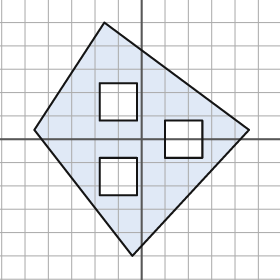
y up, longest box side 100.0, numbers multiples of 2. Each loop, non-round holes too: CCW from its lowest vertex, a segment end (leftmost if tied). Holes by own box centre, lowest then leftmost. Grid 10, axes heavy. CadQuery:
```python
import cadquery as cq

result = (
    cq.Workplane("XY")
    .moveTo(-4.0, -50.0)
    .lineTo(46.0, 4.0)
    .lineTo(-16.0, 50.0)
    .lineTo(-46.0, 4.0)
    .close()
    .moveTo(-18.0, -24.0)
    .lineTo(-2.0, -24.0)
    .lineTo(-2.0, -8.0)
    .lineTo(-18.0, -8.0)
    .close()
    .moveTo(10.0, -8.0)
    .lineTo(26.0, -8.0)
    .lineTo(26.0, 8.0)
    .lineTo(10.0, 8.0)
    .close()
    .moveTo(-18.0, 8.0)
    .lineTo(-2.0, 8.0)
    .lineTo(-2.0, 24.0)
    .lineTo(-18.0, 24.0)
    .close()
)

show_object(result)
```